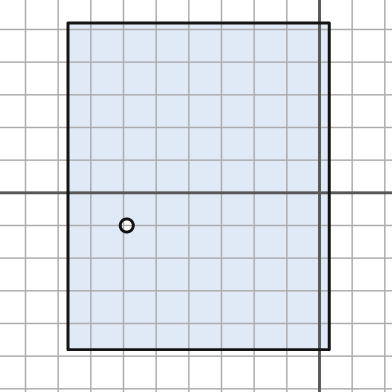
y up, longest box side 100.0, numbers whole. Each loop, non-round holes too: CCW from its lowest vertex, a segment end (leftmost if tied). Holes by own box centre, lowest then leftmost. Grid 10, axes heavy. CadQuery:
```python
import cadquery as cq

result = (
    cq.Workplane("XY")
    .moveTo(-77.0, -48.0)
    .lineTo(3.0, -48.0)
    .lineTo(3.0, 52.0)
    .lineTo(-77.0, 52.0)
    .close()
    .moveTo(-59.0, -10.0)
    .circle(2.0)
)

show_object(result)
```